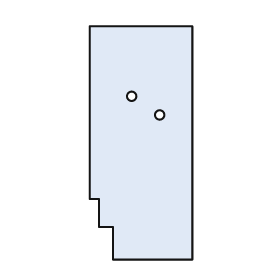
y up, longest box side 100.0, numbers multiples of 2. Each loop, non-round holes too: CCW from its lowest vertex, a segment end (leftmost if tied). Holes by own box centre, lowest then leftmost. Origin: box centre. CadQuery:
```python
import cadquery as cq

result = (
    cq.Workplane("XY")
    .moveTo(-12.0, -50.0)
    .lineTo(22.0, -50.0)
    .lineTo(22.0, 50.0)
    .lineTo(-22.0, 50.0)
    .lineTo(-22.0, -24.0)
    .lineTo(-18.0, -24.0)
    .lineTo(-18.0, -36.0)
    .lineTo(-12.0, -36.0)
    .close()
    .moveTo(8.0, 12.0)
    .circle(2.0)
    .moveTo(-4.0, 20.0)
    .circle(2.0)
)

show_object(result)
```